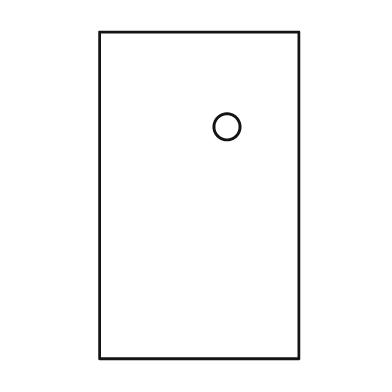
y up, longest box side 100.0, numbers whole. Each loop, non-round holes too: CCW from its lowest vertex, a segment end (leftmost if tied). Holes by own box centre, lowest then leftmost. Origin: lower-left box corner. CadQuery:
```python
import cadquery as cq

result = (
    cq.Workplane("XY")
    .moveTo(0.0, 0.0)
    .lineTo(61.0, 0.0)
    .lineTo(61.0, 100.0)
    .lineTo(0.0, 100.0)
    .close()
    .moveTo(39.0, 71.0)
    .circle(4.0)
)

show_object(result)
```